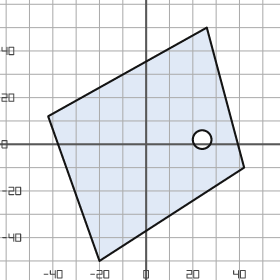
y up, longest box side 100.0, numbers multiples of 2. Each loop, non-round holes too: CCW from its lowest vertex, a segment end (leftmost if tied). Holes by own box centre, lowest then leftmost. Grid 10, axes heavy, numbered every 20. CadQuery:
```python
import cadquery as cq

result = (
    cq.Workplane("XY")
    .moveTo(-20.0, -50.0)
    .lineTo(42.0, -10.0)
    .lineTo(26.0, 50.0)
    .lineTo(-42.0, 12.0)
    .close()
    .moveTo(24.0, 2.0)
    .circle(4.0)
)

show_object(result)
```